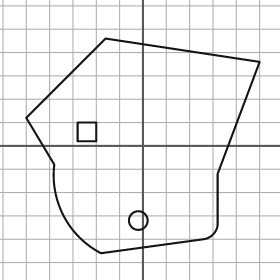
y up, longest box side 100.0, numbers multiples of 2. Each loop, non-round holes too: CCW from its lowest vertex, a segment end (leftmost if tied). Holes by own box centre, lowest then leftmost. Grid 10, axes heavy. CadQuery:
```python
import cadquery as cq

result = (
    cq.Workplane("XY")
    .moveTo(-18.0, -46.0)
    .lineTo(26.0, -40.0)
    .threePointArc((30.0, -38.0), (32.0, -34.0))
    .lineTo(32.0, -12.0)
    .lineTo(50.0, 36.0)
    .lineTo(-16.0, 46.0)
    .lineTo(-50.0, 12.0)
    .lineTo(-38.0, -8.0)
    .threePointArc((-34.0, -30.0), (-18.0, -46.0))
    .close()
    .moveTo(-2.0, -32.0)
    .circle(4.0)
    .moveTo(-28.0, 2.0)
    .lineTo(-20.0, 2.0)
    .lineTo(-20.0, 10.0)
    .lineTo(-28.0, 10.0)
    .close()
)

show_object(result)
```